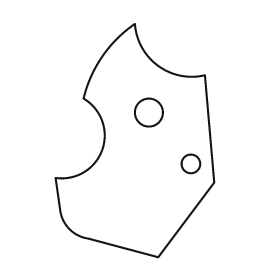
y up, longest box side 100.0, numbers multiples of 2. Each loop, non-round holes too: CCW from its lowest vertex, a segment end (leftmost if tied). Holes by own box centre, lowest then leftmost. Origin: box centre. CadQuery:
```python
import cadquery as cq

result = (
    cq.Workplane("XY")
    .moveTo(10.0, -50.0)
    .lineTo(34.0, -18.0)
    .lineTo(30.0, 28.0)
    .threePointArc((10.0, 32.0), (0.0, 50.0))
    .threePointArc((-14.0, 36.0), (-22.0, 18.0))
    .threePointArc((-14.0, -4.0), (-34.0, -16.0))
    .lineTo(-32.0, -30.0)
    .threePointArc((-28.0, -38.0), (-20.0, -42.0))
    .close()
    .moveTo(24.0, -10.0)
    .circle(4.0)
    .moveTo(6.0, 12.0)
    .circle(6.0)
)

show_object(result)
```